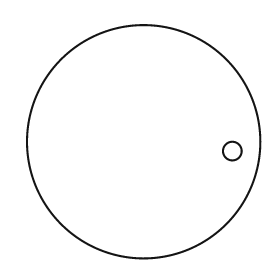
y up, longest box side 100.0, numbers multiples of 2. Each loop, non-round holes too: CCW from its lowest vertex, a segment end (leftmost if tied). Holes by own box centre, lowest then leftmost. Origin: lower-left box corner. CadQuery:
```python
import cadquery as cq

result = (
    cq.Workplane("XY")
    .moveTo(50.0, 50.0)
    .circle(50.0)
    .moveTo(88.0, 46.0)
    .circle(4.0)
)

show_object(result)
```